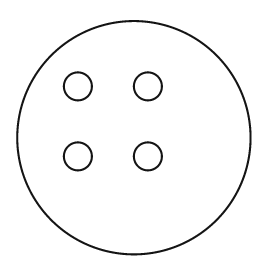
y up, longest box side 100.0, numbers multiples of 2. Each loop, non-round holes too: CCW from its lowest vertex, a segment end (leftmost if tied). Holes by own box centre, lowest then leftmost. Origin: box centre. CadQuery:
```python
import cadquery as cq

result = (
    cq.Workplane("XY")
    .moveTo(0.0, 0.0)
    .circle(50.0)
    .moveTo(-24.0, -8.0)
    .circle(6.0)
    .moveTo(6.0, -8.0)
    .circle(6.0)
    .moveTo(-24.0, 22.0)
    .circle(6.0)
    .moveTo(6.0, 22.0)
    .circle(6.0)
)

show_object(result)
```